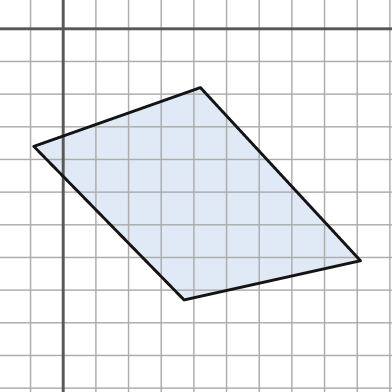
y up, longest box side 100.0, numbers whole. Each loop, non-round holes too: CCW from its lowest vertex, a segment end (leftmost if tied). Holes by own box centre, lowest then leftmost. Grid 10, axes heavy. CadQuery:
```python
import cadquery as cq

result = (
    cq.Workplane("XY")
    .moveTo(37.0, -83.0)
    .lineTo(91.0, -71.0)
    .lineTo(42.0, -18.0)
    .lineTo(-9.0, -36.0)
    .close()
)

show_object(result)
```